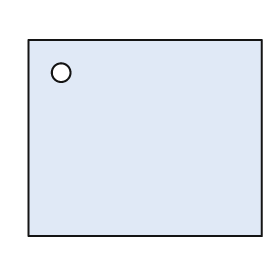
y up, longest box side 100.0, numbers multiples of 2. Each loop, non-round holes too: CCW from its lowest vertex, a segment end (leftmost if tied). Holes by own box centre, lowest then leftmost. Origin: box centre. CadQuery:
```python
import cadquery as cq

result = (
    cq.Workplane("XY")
    .moveTo(-50.0, -42.0)
    .lineTo(50.0, -42.0)
    .lineTo(50.0, 42.0)
    .lineTo(-50.0, 42.0)
    .close()
    .moveTo(-36.0, 28.0)
    .circle(4.0)
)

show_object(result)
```